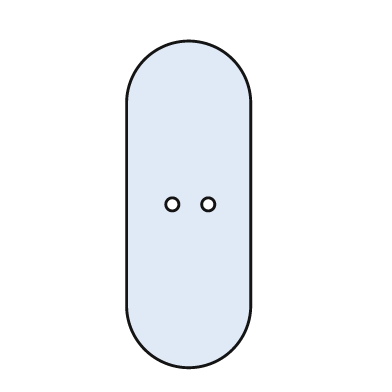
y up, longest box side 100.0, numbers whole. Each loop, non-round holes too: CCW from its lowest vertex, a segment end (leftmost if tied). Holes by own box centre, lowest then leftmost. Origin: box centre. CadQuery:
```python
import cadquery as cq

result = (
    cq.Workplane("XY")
    .moveTo(-19.0, -31.0)
    .threePointArc((0.0, -50.0), (19.0, -31.0))
    .lineTo(19.0, 31.0)
    .threePointArc((0.0, 50.0), (-19.0, 31.0))
    .close()
    .moveTo(-5.0, 0.0)
    .circle(2.0)
    .moveTo(6.0, 0.0)
    .circle(2.0)
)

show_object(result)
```